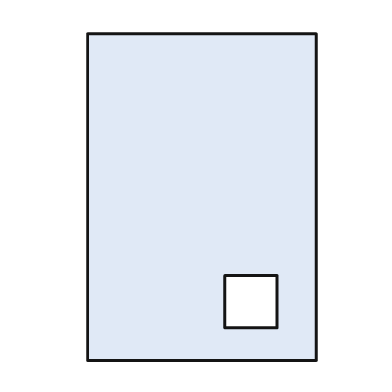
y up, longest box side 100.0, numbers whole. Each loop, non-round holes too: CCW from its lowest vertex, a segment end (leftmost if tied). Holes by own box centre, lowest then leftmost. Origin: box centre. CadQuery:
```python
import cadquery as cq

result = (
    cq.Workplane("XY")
    .moveTo(-35.0, -50.0)
    .lineTo(35.0, -50.0)
    .lineTo(35.0, 50.0)
    .lineTo(-35.0, 50.0)
    .close()
    .moveTo(7.0, -40.0)
    .lineTo(23.0, -40.0)
    .lineTo(23.0, -24.0)
    .lineTo(7.0, -24.0)
    .close()
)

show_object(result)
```